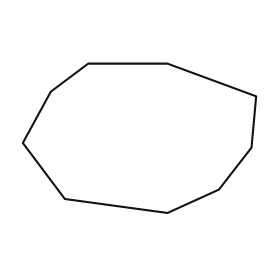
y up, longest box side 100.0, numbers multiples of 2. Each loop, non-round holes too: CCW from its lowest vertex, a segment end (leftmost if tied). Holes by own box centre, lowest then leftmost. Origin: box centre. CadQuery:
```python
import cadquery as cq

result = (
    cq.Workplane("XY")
    .moveTo(12.0, -32.0)
    .lineTo(34.0, -22.0)
    .lineTo(48.0, -4.0)
    .lineTo(50.0, 18.0)
    .lineTo(12.0, 32.0)
    .lineTo(-22.0, 32.0)
    .lineTo(-38.0, 20.0)
    .lineTo(-50.0, -2.0)
    .lineTo(-32.0, -26.0)
    .close()
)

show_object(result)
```